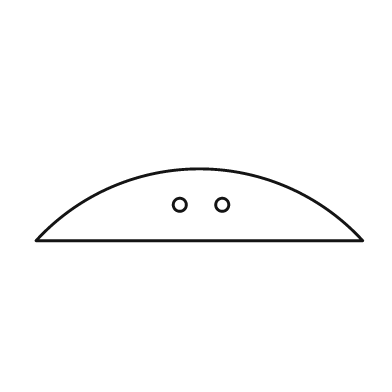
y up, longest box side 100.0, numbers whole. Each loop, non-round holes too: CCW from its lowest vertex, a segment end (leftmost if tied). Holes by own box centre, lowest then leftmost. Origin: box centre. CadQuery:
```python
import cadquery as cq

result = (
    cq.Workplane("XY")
    .moveTo(-50.0, -11.0)
    .lineTo(50.0, -11.0)
    .threePointArc((0.0, 11.0), (-50.0, -11.0))
    .close()
    .moveTo(-6.0, 0.0)
    .circle(2.0)
    .moveTo(7.0, 0.0)
    .circle(2.0)
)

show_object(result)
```